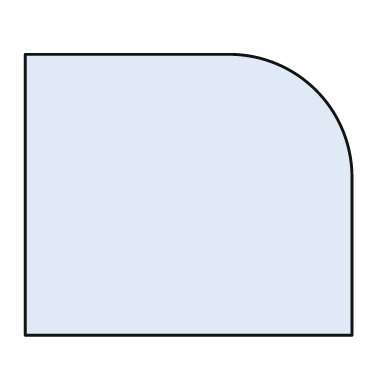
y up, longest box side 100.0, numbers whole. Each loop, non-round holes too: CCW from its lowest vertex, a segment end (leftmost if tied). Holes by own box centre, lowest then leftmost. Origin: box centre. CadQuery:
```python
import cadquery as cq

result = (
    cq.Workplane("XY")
    .moveTo(-50.0, -43.0)
    .lineTo(50.0, -43.0)
    .lineTo(50.0, 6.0)
    .threePointArc((39.0, 32.0), (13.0, 43.0))
    .lineTo(-50.0, 43.0)
    .close()
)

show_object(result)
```